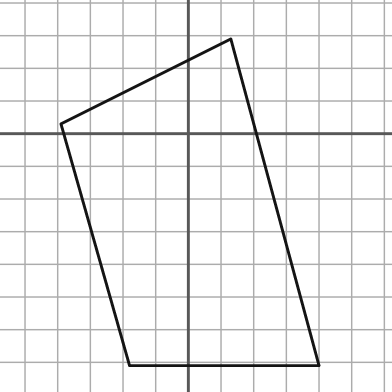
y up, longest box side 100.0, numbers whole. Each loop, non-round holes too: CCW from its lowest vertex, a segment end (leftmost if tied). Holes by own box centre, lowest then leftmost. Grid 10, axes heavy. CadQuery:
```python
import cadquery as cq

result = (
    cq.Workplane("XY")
    .moveTo(-18.0, -71.0)
    .lineTo(40.0, -71.0)
    .lineTo(13.0, 29.0)
    .lineTo(-39.0, 3.0)
    .close()
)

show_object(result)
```